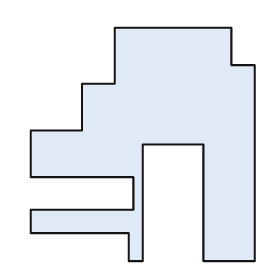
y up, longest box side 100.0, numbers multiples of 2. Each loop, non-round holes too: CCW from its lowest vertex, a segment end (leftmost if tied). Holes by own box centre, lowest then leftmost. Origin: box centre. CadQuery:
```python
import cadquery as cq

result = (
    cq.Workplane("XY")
    .moveTo(-6.0, -50.0)
    .lineTo(0.0, -50.0)
    .lineTo(0.0, 0.0)
    .lineTo(26.0, 0.0)
    .lineTo(26.0, -50.0)
    .lineTo(48.0, -50.0)
    .lineTo(48.0, 34.0)
    .lineTo(38.0, 34.0)
    .lineTo(38.0, 50.0)
    .lineTo(-12.0, 50.0)
    .lineTo(-12.0, 26.0)
    .lineTo(-26.0, 26.0)
    .lineTo(-26.0, 6.0)
    .lineTo(-48.0, 6.0)
    .lineTo(-48.0, -14.0)
    .lineTo(-4.0, -14.0)
    .lineTo(-4.0, -28.0)
    .lineTo(-48.0, -28.0)
    .lineTo(-48.0, -38.0)
    .lineTo(-6.0, -38.0)
    .close()
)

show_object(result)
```